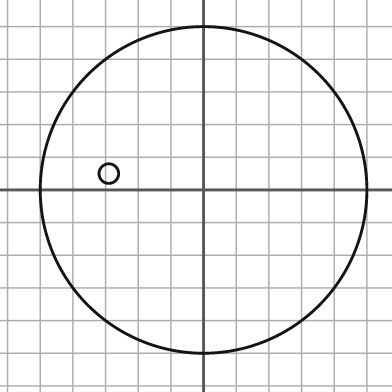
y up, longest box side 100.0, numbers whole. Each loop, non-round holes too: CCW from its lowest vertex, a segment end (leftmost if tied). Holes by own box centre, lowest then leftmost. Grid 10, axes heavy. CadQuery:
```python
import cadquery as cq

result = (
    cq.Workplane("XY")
    .moveTo(0.0, 0.0)
    .circle(50.0)
    .moveTo(-29.0, 5.0)
    .circle(3.0)
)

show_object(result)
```